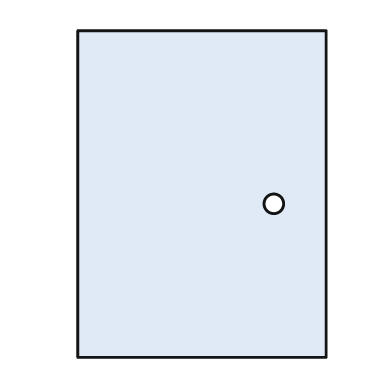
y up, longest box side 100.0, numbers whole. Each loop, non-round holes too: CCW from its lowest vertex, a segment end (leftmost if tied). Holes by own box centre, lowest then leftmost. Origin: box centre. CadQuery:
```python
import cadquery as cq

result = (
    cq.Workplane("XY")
    .moveTo(-38.0, -50.0)
    .lineTo(38.0, -50.0)
    .lineTo(38.0, 50.0)
    .lineTo(-38.0, 50.0)
    .close()
    .moveTo(22.0, -3.0)
    .circle(3.0)
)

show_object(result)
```